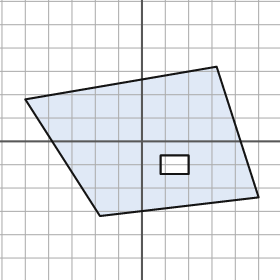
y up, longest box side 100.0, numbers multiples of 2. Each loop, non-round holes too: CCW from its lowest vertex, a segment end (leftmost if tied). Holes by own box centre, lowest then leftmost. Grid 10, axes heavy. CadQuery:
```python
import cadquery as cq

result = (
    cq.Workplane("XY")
    .moveTo(-18.0, -32.0)
    .lineTo(50.0, -24.0)
    .lineTo(32.0, 32.0)
    .lineTo(-50.0, 18.0)
    .close()
    .moveTo(8.0, -14.0)
    .lineTo(20.0, -14.0)
    .lineTo(20.0, -6.0)
    .lineTo(8.0, -6.0)
    .close()
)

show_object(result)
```